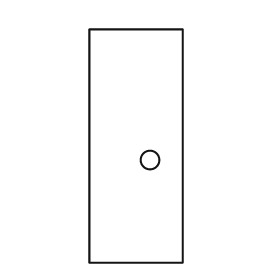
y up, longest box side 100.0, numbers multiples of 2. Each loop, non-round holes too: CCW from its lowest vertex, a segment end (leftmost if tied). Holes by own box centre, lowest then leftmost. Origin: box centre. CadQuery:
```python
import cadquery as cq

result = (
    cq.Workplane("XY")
    .moveTo(-20.0, -50.0)
    .lineTo(20.0, -50.0)
    .lineTo(20.0, 50.0)
    .lineTo(-20.0, 50.0)
    .close()
    .moveTo(6.0, -6.0)
    .circle(4.0)
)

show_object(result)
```